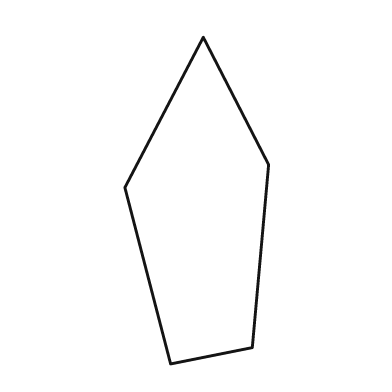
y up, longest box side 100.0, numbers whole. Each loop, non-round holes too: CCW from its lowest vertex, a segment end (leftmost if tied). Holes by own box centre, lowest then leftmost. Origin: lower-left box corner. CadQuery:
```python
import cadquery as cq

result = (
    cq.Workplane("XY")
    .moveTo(14.0, 0.0)
    .lineTo(39.0, 5.0)
    .lineTo(44.0, 61.0)
    .lineTo(24.0, 100.0)
    .lineTo(0.0, 54.0)
    .close()
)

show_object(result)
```